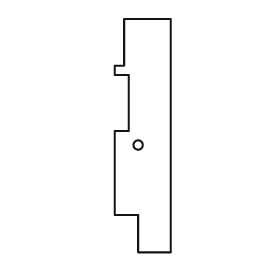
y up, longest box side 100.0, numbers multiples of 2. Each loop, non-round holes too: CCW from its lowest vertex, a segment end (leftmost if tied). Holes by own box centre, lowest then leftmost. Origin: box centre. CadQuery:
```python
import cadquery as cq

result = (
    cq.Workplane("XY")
    .moveTo(-2.0, -50.0)
    .lineTo(12.0, -50.0)
    .lineTo(12.0, 50.0)
    .lineTo(-8.0, 50.0)
    .lineTo(-8.0, 30.0)
    .lineTo(-12.0, 30.0)
    .lineTo(-12.0, 26.0)
    .lineTo(-6.0, 26.0)
    .lineTo(-6.0, 2.0)
    .lineTo(-12.0, 2.0)
    .lineTo(-12.0, -34.0)
    .lineTo(-2.0, -34.0)
    .close()
    .moveTo(-2.0, -4.0)
    .circle(2.0)
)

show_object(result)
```